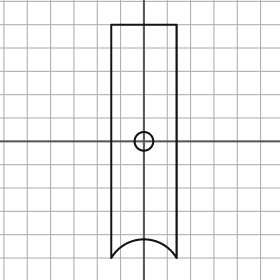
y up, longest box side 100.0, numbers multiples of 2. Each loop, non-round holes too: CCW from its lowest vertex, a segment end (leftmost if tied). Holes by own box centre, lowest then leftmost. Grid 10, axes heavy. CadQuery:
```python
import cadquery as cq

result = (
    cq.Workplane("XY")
    .moveTo(-14.0, -50.0)
    .threePointArc((0.0, -42.0), (14.0, -50.0))
    .lineTo(14.0, 50.0)
    .lineTo(-14.0, 50.0)
    .close()
    .moveTo(0.0, 0.0)
    .circle(4.0)
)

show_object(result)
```